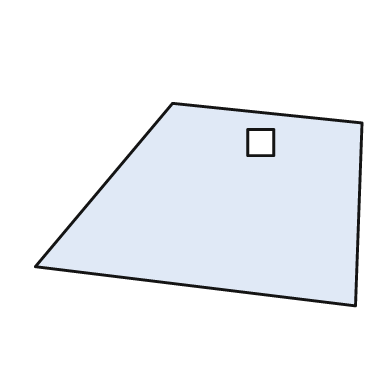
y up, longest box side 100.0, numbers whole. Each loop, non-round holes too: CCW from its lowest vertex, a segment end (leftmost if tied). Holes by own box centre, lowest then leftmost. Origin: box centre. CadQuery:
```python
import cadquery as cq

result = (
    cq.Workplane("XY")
    .moveTo(48.0, -31.0)
    .lineTo(50.0, 25.0)
    .lineTo(-8.0, 31.0)
    .lineTo(-50.0, -19.0)
    .close()
    .moveTo(15.0, 15.0)
    .lineTo(23.0, 15.0)
    .lineTo(23.0, 23.0)
    .lineTo(15.0, 23.0)
    .close()
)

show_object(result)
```